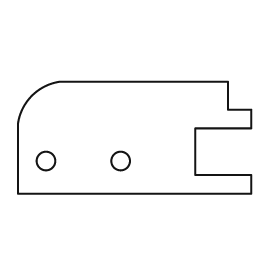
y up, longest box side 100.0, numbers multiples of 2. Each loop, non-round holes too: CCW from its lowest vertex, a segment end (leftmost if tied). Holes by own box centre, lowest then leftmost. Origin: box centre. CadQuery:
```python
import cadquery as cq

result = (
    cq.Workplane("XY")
    .moveTo(-50.0, -24.0)
    .lineTo(50.0, -24.0)
    .lineTo(50.0, -16.0)
    .lineTo(26.0, -16.0)
    .lineTo(26.0, 4.0)
    .lineTo(50.0, 4.0)
    .lineTo(50.0, 12.0)
    .lineTo(40.0, 12.0)
    .lineTo(40.0, 24.0)
    .lineTo(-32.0, 24.0)
    .threePointArc((-44.0, 18.0), (-50.0, 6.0))
    .close()
    .moveTo(-38.0, -10.0)
    .circle(4.0)
    .moveTo(-6.0, -10.0)
    .circle(4.0)
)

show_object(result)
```